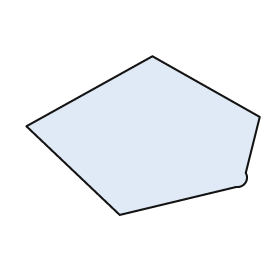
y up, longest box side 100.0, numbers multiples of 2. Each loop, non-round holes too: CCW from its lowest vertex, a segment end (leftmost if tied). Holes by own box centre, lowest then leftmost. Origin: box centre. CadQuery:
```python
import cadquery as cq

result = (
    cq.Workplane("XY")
    .moveTo(-10.0, -34.0)
    .lineTo(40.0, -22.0)
    .threePointArc((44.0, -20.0), (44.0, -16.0))
    .lineTo(50.0, 8.0)
    .lineTo(4.0, 34.0)
    .lineTo(-50.0, 4.0)
    .close()
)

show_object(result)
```